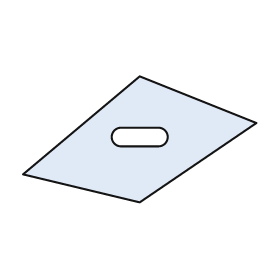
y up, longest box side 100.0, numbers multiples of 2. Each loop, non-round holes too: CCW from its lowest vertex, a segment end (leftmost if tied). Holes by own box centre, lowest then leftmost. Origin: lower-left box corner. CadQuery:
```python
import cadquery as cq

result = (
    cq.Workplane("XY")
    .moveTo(50.0, 0.0)
    .lineTo(100.0, 34.0)
    .lineTo(50.0, 54.0)
    .lineTo(0.0, 12.0)
    .close()
    .moveTo(42.0, 24.0)
    .lineTo(58.0, 24.0)
    .threePointArc((62.0, 28.0), (58.0, 32.0))
    .lineTo(42.0, 32.0)
    .threePointArc((38.0, 28.0), (42.0, 24.0))
    .close()
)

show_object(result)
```